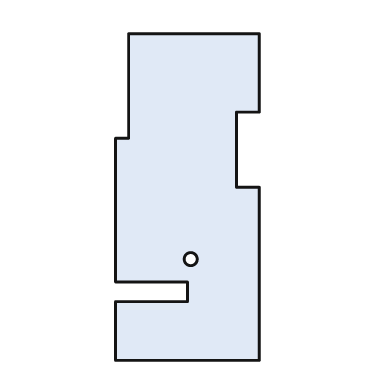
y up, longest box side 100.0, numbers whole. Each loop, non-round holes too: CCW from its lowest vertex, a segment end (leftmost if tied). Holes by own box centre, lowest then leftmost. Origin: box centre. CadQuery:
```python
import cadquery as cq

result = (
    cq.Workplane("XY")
    .moveTo(-22.0, -50.0)
    .lineTo(22.0, -50.0)
    .lineTo(22.0, 3.0)
    .lineTo(15.0, 3.0)
    .lineTo(15.0, 26.0)
    .lineTo(22.0, 26.0)
    .lineTo(22.0, 50.0)
    .lineTo(-18.0, 50.0)
    .lineTo(-18.0, 18.0)
    .lineTo(-22.0, 18.0)
    .lineTo(-22.0, -26.0)
    .lineTo(0.0, -26.0)
    .lineTo(0.0, -32.0)
    .lineTo(-22.0, -32.0)
    .close()
    .moveTo(1.0, -19.0)
    .circle(2.0)
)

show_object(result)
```